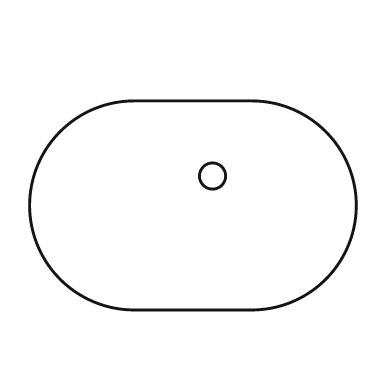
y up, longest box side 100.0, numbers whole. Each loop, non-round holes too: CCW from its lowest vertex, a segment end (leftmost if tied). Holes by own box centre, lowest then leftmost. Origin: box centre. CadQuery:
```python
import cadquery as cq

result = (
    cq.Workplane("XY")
    .moveTo(-18.0, -32.0)
    .lineTo(18.0, -32.0)
    .threePointArc((50.0, 0.0), (18.0, 32.0))
    .lineTo(-18.0, 32.0)
    .threePointArc((-50.0, 0.0), (-18.0, -32.0))
    .close()
    .moveTo(6.0, 9.0)
    .circle(4.0)
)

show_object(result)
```